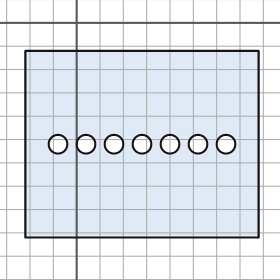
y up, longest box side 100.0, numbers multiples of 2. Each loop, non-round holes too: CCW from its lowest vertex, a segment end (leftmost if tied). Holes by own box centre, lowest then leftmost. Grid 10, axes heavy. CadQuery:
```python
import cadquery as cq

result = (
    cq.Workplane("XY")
    .moveTo(-22.0, -92.0)
    .lineTo(78.0, -92.0)
    .lineTo(78.0, -12.0)
    .lineTo(-22.0, -12.0)
    .close()
    .moveTo(-8.0, -52.0)
    .circle(4.0)
    .moveTo(4.0, -52.0)
    .circle(4.0)
    .moveTo(16.0, -52.0)
    .circle(4.0)
    .moveTo(28.0, -52.0)
    .circle(4.0)
    .moveTo(40.0, -52.0)
    .circle(4.0)
    .moveTo(52.0, -52.0)
    .circle(4.0)
    .moveTo(64.0, -52.0)
    .circle(4.0)
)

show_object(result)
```